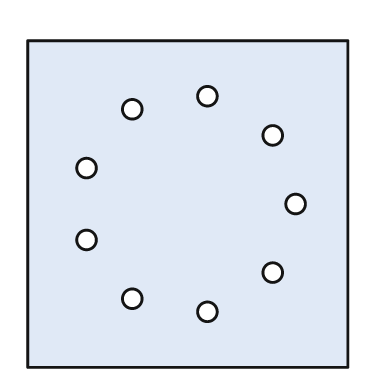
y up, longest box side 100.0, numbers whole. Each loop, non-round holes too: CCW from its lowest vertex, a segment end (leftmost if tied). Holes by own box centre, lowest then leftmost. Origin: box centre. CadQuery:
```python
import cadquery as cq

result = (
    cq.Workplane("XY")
    .moveTo(-49.0, -50.0)
    .lineTo(49.0, -50.0)
    .lineTo(49.0, 50.0)
    .lineTo(-49.0, 50.0)
    .close()
    .moveTo(6.0, -33.0)
    .circle(3.0)
    .moveTo(-17.0, -29.0)
    .circle(3.0)
    .moveTo(26.0, -21.0)
    .circle(3.0)
    .moveTo(-31.0, -11.0)
    .circle(3.0)
    .moveTo(33.0, 0.0)
    .circle(3.0)
    .moveTo(-31.0, 11.0)
    .circle(3.0)
    .moveTo(26.0, 21.0)
    .circle(3.0)
    .moveTo(-17.0, 29.0)
    .circle(3.0)
    .moveTo(6.0, 33.0)
    .circle(3.0)
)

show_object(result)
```